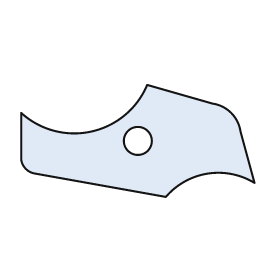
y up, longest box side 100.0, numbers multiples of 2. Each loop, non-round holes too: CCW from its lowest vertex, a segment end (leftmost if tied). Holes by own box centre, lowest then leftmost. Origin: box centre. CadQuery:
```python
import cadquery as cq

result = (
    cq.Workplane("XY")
    .moveTo(12.0, -24.0)
    .threePointArc((30.0, -14.0), (50.0, -18.0))
    .lineTo(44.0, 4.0)
    .threePointArc((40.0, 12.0), (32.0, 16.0))
    .lineTo(4.0, 24.0)
    .threePointArc((-20.0, 4.0), (-50.0, 12.0))
    .lineTo(-50.0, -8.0)
    .threePointArc((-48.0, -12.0), (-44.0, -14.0))
    .close()
    .moveTo(0.0, 0.0)
    .circle(6.0)
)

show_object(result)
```